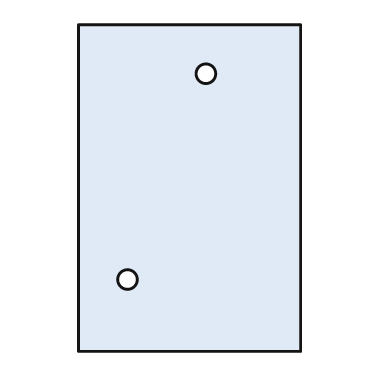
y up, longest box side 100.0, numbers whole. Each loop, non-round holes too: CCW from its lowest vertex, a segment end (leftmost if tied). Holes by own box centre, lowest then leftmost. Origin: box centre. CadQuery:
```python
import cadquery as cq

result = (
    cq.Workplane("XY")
    .moveTo(-34.0, -50.0)
    .lineTo(34.0, -50.0)
    .lineTo(34.0, 50.0)
    .lineTo(-34.0, 50.0)
    .close()
    .moveTo(-19.0, -28.0)
    .circle(3.0)
    .moveTo(5.0, 35.0)
    .circle(3.0)
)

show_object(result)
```